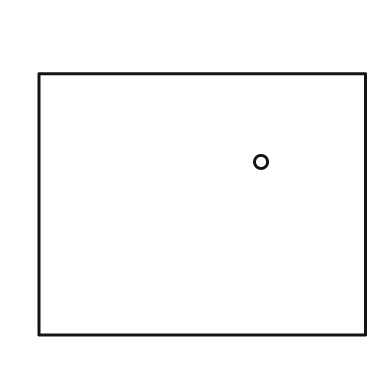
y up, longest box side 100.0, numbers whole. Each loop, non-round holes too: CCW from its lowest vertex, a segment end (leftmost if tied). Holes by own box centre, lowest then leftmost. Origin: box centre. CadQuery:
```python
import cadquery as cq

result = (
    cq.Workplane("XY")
    .moveTo(-50.0, -40.0)
    .lineTo(50.0, -40.0)
    .lineTo(50.0, 40.0)
    .lineTo(-50.0, 40.0)
    .close()
    .moveTo(18.0, 13.0)
    .circle(2.0)
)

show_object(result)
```